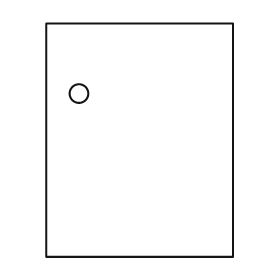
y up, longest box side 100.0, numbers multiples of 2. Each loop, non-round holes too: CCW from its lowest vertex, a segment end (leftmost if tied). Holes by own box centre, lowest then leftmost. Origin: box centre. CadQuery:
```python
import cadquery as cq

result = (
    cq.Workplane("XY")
    .moveTo(-40.0, -50.0)
    .lineTo(40.0, -50.0)
    .lineTo(40.0, 50.0)
    .lineTo(-40.0, 50.0)
    .close()
    .moveTo(-26.0, 20.0)
    .circle(4.0)
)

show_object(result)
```